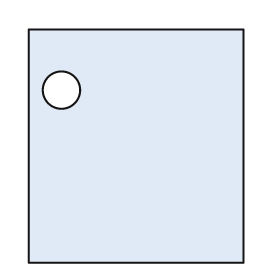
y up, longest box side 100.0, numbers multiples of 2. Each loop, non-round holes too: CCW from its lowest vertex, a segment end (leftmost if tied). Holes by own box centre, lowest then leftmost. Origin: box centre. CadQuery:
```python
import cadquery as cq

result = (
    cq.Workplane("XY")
    .moveTo(-46.0, -50.0)
    .lineTo(46.0, -50.0)
    .lineTo(46.0, 50.0)
    .lineTo(-46.0, 50.0)
    .close()
    .moveTo(-32.0, 24.0)
    .circle(8.0)
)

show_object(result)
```